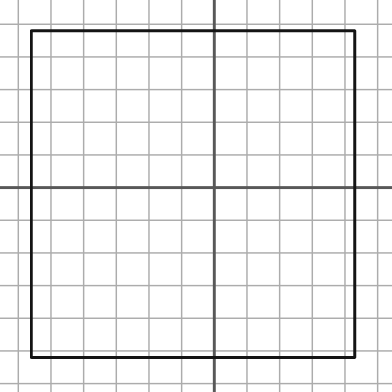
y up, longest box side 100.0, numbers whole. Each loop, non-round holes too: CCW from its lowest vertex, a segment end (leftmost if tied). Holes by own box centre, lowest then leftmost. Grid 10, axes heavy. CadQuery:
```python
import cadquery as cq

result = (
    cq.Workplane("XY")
    .moveTo(-56.0, -52.0)
    .lineTo(43.0, -52.0)
    .lineTo(43.0, 48.0)
    .lineTo(-56.0, 48.0)
    .close()
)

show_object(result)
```